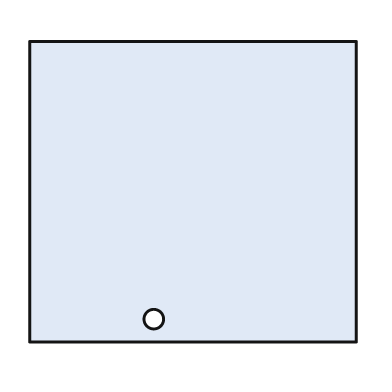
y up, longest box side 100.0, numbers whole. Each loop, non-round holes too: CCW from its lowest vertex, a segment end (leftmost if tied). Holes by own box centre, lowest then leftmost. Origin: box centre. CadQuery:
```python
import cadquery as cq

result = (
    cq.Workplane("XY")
    .moveTo(-50.0, -46.0)
    .lineTo(50.0, -46.0)
    .lineTo(50.0, 46.0)
    .lineTo(-50.0, 46.0)
    .close()
    .moveTo(-12.0, -39.0)
    .circle(3.0)
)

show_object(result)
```